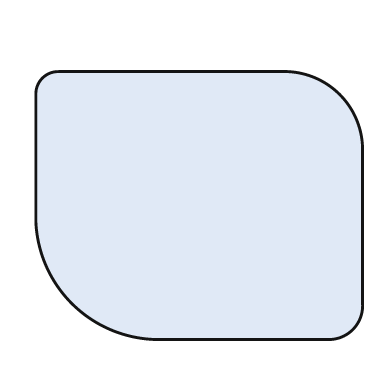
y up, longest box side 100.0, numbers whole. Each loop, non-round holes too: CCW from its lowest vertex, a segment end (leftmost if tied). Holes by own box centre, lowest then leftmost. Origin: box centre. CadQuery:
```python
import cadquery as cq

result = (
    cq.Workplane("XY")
    .moveTo(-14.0, -41.0)
    .lineTo(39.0, -41.0)
    .threePointArc((47.0, -38.0), (50.0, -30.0))
    .lineTo(50.0, 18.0)
    .threePointArc((43.0, 34.0), (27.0, 41.0))
    .lineTo(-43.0, 41.0)
    .threePointArc((-48.0, 39.0), (-50.0, 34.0))
    .lineTo(-50.0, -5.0)
    .threePointArc((-39.0, -30.0), (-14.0, -41.0))
    .close()
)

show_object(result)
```